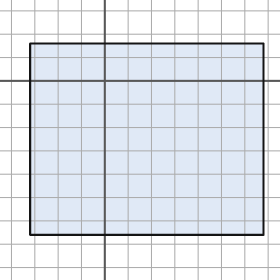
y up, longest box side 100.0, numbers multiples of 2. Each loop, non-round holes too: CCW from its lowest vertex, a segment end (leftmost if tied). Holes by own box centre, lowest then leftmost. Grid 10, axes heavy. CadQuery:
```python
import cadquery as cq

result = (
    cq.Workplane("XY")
    .moveTo(-32.0, -66.0)
    .lineTo(68.0, -66.0)
    .lineTo(68.0, 16.0)
    .lineTo(-32.0, 16.0)
    .close()
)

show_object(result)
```